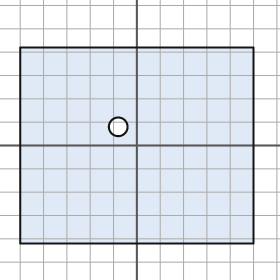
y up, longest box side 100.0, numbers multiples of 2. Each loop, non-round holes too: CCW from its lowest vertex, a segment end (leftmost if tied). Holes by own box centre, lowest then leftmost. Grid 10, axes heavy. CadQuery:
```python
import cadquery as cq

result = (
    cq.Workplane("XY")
    .moveTo(-50.0, -42.0)
    .lineTo(50.0, -42.0)
    .lineTo(50.0, 42.0)
    .lineTo(-50.0, 42.0)
    .close()
    .moveTo(-8.0, 8.0)
    .circle(4.0)
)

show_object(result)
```